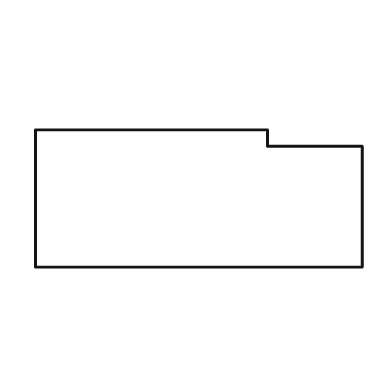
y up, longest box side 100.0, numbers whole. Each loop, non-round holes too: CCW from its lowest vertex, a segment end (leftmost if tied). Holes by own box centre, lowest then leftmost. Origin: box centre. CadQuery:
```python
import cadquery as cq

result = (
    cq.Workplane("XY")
    .moveTo(-50.0, -21.0)
    .lineTo(50.0, -21.0)
    .lineTo(50.0, 16.0)
    .lineTo(21.0, 16.0)
    .lineTo(21.0, 21.0)
    .lineTo(-50.0, 21.0)
    .close()
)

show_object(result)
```